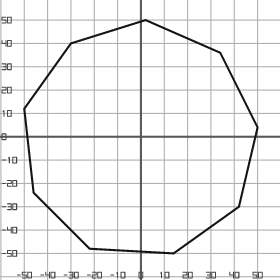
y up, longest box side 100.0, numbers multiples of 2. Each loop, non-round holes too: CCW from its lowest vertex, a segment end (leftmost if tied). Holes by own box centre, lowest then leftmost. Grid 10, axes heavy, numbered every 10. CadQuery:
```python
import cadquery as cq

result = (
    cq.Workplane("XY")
    .moveTo(14.0, -50.0)
    .lineTo(42.0, -30.0)
    .lineTo(50.0, 4.0)
    .lineTo(34.0, 36.0)
    .lineTo(2.0, 50.0)
    .lineTo(-30.0, 40.0)
    .lineTo(-50.0, 12.0)
    .lineTo(-46.0, -24.0)
    .lineTo(-22.0, -48.0)
    .close()
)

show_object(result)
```